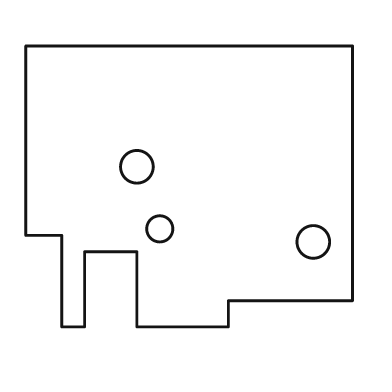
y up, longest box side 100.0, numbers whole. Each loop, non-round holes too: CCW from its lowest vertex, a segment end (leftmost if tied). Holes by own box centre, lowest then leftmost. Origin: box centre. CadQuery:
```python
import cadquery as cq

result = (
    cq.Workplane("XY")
    .moveTo(-39.0, -43.0)
    .lineTo(-32.0, -43.0)
    .lineTo(-32.0, -20.0)
    .lineTo(-16.0, -20.0)
    .lineTo(-16.0, -43.0)
    .lineTo(12.0, -43.0)
    .lineTo(12.0, -35.0)
    .lineTo(50.0, -35.0)
    .lineTo(50.0, 43.0)
    .lineTo(-50.0, 43.0)
    .lineTo(-50.0, -15.0)
    .lineTo(-39.0, -15.0)
    .close()
    .moveTo(38.0, -17.0)
    .circle(5.0)
    .moveTo(-9.0, -13.0)
    .circle(4.0)
    .moveTo(-16.0, 6.0)
    .circle(5.0)
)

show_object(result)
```